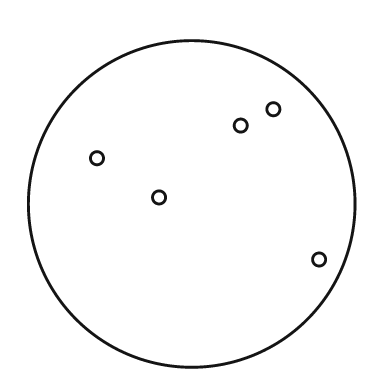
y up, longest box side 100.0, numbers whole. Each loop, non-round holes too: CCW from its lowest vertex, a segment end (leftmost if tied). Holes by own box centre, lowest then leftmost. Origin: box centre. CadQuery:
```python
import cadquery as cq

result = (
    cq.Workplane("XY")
    .moveTo(0.0, 0.0)
    .circle(50.0)
    .moveTo(39.0, -17.0)
    .circle(2.0)
    .moveTo(-10.0, 2.0)
    .circle(2.0)
    .moveTo(-29.0, 14.0)
    .circle(2.0)
    .moveTo(15.0, 24.0)
    .circle(2.0)
    .moveTo(25.0, 29.0)
    .circle(2.0)
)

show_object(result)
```